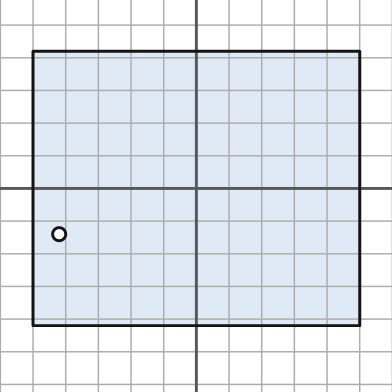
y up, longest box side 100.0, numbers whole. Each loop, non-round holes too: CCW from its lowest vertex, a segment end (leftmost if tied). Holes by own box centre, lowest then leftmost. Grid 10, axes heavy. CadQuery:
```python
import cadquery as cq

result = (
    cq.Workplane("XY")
    .moveTo(-50.0, -42.0)
    .lineTo(50.0, -42.0)
    .lineTo(50.0, 42.0)
    .lineTo(-50.0, 42.0)
    .close()
    .moveTo(-42.0, -14.0)
    .circle(2.0)
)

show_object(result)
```